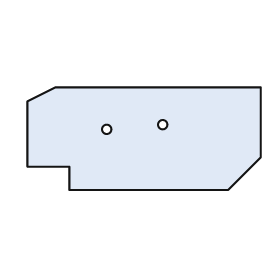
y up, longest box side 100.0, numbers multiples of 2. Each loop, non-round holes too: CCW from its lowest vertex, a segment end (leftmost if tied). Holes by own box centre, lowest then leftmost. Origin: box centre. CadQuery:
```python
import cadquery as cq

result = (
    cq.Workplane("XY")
    .moveTo(-32.0, -22.0)
    .lineTo(36.0, -22.0)
    .lineTo(50.0, -8.0)
    .lineTo(50.0, 22.0)
    .lineTo(-38.0, 22.0)
    .lineTo(-50.0, 16.0)
    .lineTo(-50.0, -12.0)
    .lineTo(-32.0, -12.0)
    .close()
    .moveTo(-16.0, 4.0)
    .circle(2.0)
    .moveTo(8.0, 6.0)
    .circle(2.0)
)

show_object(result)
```